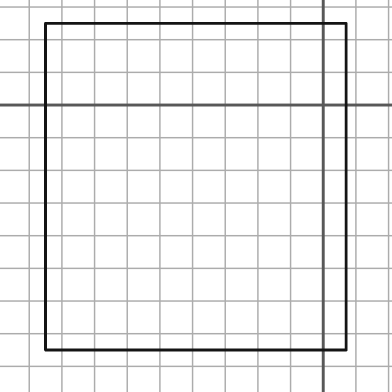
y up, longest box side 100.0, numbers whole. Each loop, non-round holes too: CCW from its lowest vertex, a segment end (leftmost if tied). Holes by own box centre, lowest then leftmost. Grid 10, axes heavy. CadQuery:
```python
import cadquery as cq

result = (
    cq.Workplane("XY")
    .moveTo(-85.0, -75.0)
    .lineTo(7.0, -75.0)
    .lineTo(7.0, 25.0)
    .lineTo(-85.0, 25.0)
    .close()
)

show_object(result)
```